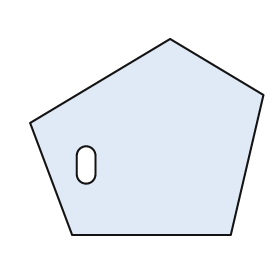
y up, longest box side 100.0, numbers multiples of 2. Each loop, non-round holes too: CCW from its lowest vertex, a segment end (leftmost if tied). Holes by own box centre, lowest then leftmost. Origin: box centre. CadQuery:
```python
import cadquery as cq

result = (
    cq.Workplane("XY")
    .moveTo(-32.0, -42.0)
    .lineTo(36.0, -42.0)
    .lineTo(50.0, 18.0)
    .lineTo(10.0, 42.0)
    .lineTo(-50.0, 6.0)
    .close()
    .moveTo(-30.0, -16.0)
    .threePointArc((-26.0, -20.0), (-22.0, -16.0))
    .lineTo(-22.0, -8.0)
    .threePointArc((-26.0, -4.0), (-30.0, -8.0))
    .close()
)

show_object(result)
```